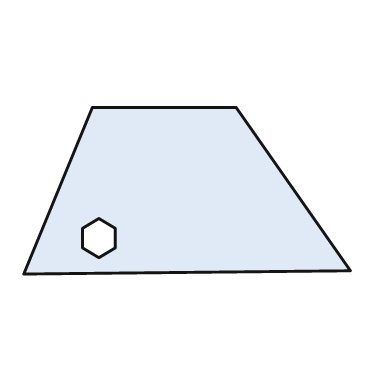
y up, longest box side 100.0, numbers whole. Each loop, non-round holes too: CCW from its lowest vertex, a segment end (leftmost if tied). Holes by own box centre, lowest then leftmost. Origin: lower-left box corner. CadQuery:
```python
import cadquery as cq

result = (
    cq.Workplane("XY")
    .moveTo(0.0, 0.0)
    .lineTo(100.0, 1.0)
    .lineTo(65.0, 51.0)
    .lineTo(21.0, 51.0)
    .close()
    .moveTo(23.0, 5.0)
    .lineTo(28.0, 8.0)
    .lineTo(28.0, 14.0)
    .lineTo(23.0, 17.0)
    .lineTo(18.0, 14.0)
    .lineTo(18.0, 8.0)
    .close()
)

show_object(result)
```